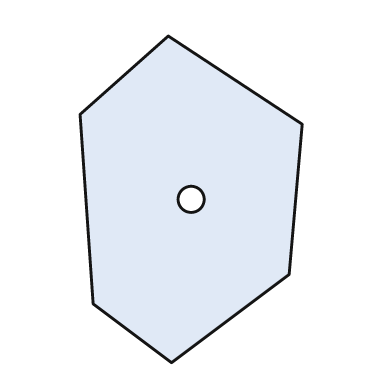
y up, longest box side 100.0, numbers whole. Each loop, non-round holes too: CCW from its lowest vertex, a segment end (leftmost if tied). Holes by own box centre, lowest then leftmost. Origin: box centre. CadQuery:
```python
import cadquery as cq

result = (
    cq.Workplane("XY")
    .moveTo(-6.0, -50.0)
    .lineTo(30.0, -23.0)
    .lineTo(34.0, 23.0)
    .lineTo(-7.0, 50.0)
    .lineTo(-34.0, 26.0)
    .lineTo(-30.0, -32.0)
    .close()
    .moveTo(0.0, 0.0)
    .circle(4.0)
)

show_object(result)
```